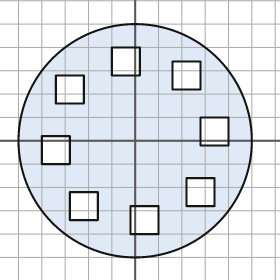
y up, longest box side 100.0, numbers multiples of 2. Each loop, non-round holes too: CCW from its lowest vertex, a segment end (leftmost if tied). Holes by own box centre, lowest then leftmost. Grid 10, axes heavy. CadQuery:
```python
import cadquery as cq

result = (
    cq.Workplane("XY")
    .moveTo(0.0, 0.0)
    .circle(50.0)
    .moveTo(-2.0, -40.0)
    .lineTo(10.0, -40.0)
    .lineTo(10.0, -28.0)
    .lineTo(-2.0, -28.0)
    .close()
    .moveTo(-28.0, -34.0)
    .lineTo(-16.0, -34.0)
    .lineTo(-16.0, -22.0)
    .lineTo(-28.0, -22.0)
    .close()
    .moveTo(22.0, -28.0)
    .lineTo(34.0, -28.0)
    .lineTo(34.0, -16.0)
    .lineTo(22.0, -16.0)
    .close()
    .moveTo(-40.0, -10.0)
    .lineTo(-28.0, -10.0)
    .lineTo(-28.0, 2.0)
    .lineTo(-40.0, 2.0)
    .close()
    .moveTo(28.0, -2.0)
    .lineTo(40.0, -2.0)
    .lineTo(40.0, 10.0)
    .lineTo(28.0, 10.0)
    .close()
    .moveTo(-34.0, 16.0)
    .lineTo(-22.0, 16.0)
    .lineTo(-22.0, 28.0)
    .lineTo(-34.0, 28.0)
    .close()
    .moveTo(16.0, 22.0)
    .lineTo(28.0, 22.0)
    .lineTo(28.0, 34.0)
    .lineTo(16.0, 34.0)
    .close()
    .moveTo(-10.0, 28.0)
    .lineTo(2.0, 28.0)
    .lineTo(2.0, 40.0)
    .lineTo(-10.0, 40.0)
    .close()
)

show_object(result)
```